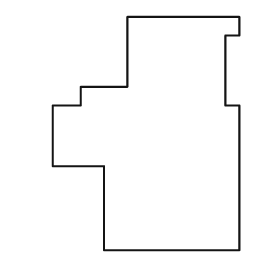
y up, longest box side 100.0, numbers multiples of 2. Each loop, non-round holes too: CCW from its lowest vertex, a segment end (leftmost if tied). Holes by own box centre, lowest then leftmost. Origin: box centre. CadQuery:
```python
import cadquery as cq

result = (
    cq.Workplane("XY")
    .moveTo(-18.0, -50.0)
    .lineTo(40.0, -50.0)
    .lineTo(40.0, 12.0)
    .lineTo(34.0, 12.0)
    .lineTo(34.0, 42.0)
    .lineTo(40.0, 42.0)
    .lineTo(40.0, 50.0)
    .lineTo(-8.0, 50.0)
    .lineTo(-8.0, 20.0)
    .lineTo(-28.0, 20.0)
    .lineTo(-28.0, 12.0)
    .lineTo(-40.0, 12.0)
    .lineTo(-40.0, -14.0)
    .lineTo(-18.0, -14.0)
    .close()
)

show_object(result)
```